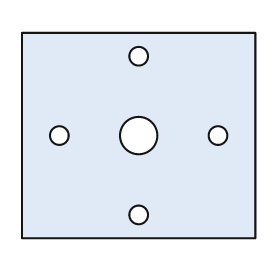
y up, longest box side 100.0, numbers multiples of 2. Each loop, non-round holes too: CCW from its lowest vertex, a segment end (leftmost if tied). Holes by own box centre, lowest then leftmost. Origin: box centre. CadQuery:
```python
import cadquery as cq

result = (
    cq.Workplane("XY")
    .moveTo(-50.0, -44.0)
    .lineTo(50.0, -44.0)
    .lineTo(50.0, 44.0)
    .lineTo(-50.0, 44.0)
    .close()
    .moveTo(0.0, -34.0)
    .circle(4.0)
    .moveTo(-34.0, 0.0)
    .circle(4.0)
    .moveTo(0.0, 0.0)
    .circle(8.0)
    .moveTo(34.0, 0.0)
    .circle(4.0)
    .moveTo(0.0, 34.0)
    .circle(4.0)
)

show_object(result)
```